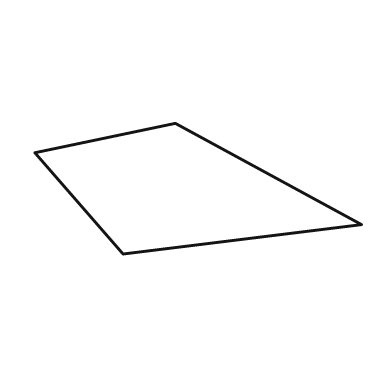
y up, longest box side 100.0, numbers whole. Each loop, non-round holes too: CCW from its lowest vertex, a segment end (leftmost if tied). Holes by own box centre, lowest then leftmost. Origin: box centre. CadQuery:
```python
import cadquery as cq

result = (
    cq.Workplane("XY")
    .moveTo(-23.0, -20.0)
    .lineTo(50.0, -11.0)
    .lineTo(-7.0, 20.0)
    .lineTo(-50.0, 11.0)
    .close()
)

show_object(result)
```